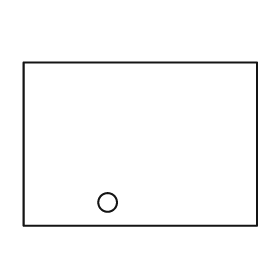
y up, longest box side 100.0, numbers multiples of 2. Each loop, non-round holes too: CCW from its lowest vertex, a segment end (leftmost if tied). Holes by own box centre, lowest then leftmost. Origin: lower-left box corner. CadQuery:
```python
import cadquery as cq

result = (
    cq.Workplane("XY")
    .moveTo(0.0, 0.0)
    .lineTo(100.0, 0.0)
    .lineTo(100.0, 70.0)
    .lineTo(0.0, 70.0)
    .close()
    .moveTo(36.0, 10.0)
    .circle(4.0)
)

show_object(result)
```